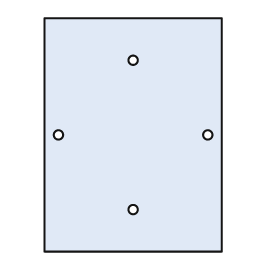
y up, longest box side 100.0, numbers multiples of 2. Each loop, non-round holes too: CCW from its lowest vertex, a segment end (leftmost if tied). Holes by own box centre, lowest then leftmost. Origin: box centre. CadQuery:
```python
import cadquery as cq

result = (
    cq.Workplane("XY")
    .moveTo(-38.0, -50.0)
    .lineTo(38.0, -50.0)
    .lineTo(38.0, 50.0)
    .lineTo(-38.0, 50.0)
    .close()
    .moveTo(0.0, -32.0)
    .circle(2.0)
    .moveTo(-32.0, 0.0)
    .circle(2.0)
    .moveTo(32.0, 0.0)
    .circle(2.0)
    .moveTo(0.0, 32.0)
    .circle(2.0)
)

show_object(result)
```